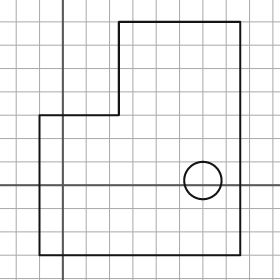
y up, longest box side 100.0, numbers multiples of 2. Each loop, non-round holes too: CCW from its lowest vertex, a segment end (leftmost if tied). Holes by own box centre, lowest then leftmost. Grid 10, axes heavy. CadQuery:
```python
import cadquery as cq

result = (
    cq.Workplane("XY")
    .moveTo(-10.0, -30.0)
    .lineTo(76.0, -30.0)
    .lineTo(76.0, 70.0)
    .lineTo(24.0, 70.0)
    .lineTo(24.0, 30.0)
    .lineTo(-10.0, 30.0)
    .close()
    .moveTo(60.0, 2.0)
    .circle(8.0)
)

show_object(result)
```